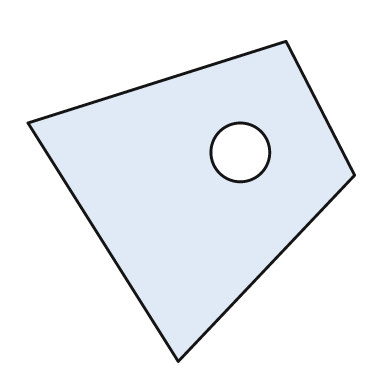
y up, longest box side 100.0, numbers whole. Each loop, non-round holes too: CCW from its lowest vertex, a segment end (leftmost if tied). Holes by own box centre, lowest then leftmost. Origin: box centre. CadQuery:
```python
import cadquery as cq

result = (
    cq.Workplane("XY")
    .moveTo(-4.0, -49.0)
    .lineTo(50.0, 8.0)
    .lineTo(29.0, 49.0)
    .lineTo(-50.0, 24.0)
    .close()
    .moveTo(15.0, 15.0)
    .circle(9.0)
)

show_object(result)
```